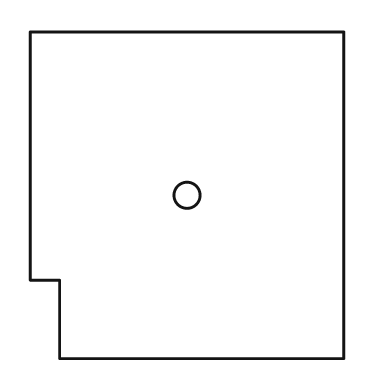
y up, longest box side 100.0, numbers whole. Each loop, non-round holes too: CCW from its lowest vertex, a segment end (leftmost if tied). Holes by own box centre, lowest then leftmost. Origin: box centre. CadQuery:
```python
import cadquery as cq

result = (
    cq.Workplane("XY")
    .moveTo(-39.0, -50.0)
    .lineTo(48.0, -50.0)
    .lineTo(48.0, 50.0)
    .lineTo(-48.0, 50.0)
    .lineTo(-48.0, -26.0)
    .lineTo(-39.0, -26.0)
    .close()
    .moveTo(0.0, 0.0)
    .circle(4.0)
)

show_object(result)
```